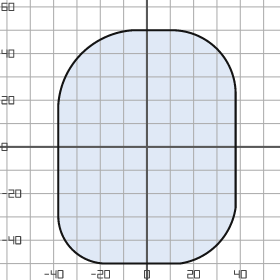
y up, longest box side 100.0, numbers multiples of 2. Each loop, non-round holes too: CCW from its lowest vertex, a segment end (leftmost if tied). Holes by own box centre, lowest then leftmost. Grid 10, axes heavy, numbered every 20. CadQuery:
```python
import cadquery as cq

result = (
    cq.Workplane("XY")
    .moveTo(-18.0, -50.0)
    .lineTo(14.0, -50.0)
    .threePointArc((30.0, -42.0), (38.0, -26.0))
    .lineTo(38.0, 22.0)
    .threePointArc((30.0, 42.0), (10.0, 50.0))
    .lineTo(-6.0, 50.0)
    .threePointArc((-28.0, 40.0), (-38.0, 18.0))
    .lineTo(-38.0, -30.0)
    .threePointArc((-32.0, -44.0), (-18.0, -50.0))
    .close()
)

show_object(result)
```